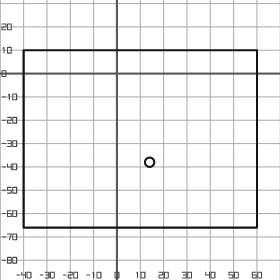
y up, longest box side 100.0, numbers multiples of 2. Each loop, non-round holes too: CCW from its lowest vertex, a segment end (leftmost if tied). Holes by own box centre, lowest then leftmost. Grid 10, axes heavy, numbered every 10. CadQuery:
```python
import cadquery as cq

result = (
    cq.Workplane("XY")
    .moveTo(-40.0, -66.0)
    .lineTo(60.0, -66.0)
    .lineTo(60.0, 10.0)
    .lineTo(-40.0, 10.0)
    .close()
    .moveTo(14.0, -38.0)
    .circle(2.0)
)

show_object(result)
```